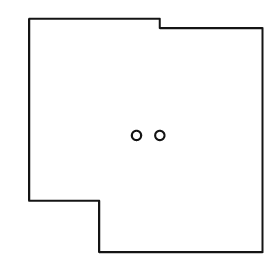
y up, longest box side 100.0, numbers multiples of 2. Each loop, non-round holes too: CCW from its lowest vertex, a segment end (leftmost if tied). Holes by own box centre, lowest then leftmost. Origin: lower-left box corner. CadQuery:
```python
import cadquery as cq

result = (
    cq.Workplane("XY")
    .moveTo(30.0, 0.0)
    .lineTo(100.0, 0.0)
    .lineTo(100.0, 96.0)
    .lineTo(56.0, 96.0)
    .lineTo(56.0, 100.0)
    .lineTo(0.0, 100.0)
    .lineTo(0.0, 22.0)
    .lineTo(30.0, 22.0)
    .close()
    .moveTo(46.0, 50.0)
    .circle(2.0)
    .moveTo(56.0, 50.0)
    .circle(2.0)
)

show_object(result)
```